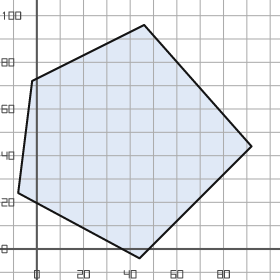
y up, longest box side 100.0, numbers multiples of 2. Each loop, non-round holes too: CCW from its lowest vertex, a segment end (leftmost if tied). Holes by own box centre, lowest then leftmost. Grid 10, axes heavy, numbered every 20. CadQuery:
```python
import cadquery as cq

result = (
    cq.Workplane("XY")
    .moveTo(44.0, -4.0)
    .lineTo(92.0, 44.0)
    .lineTo(46.0, 96.0)
    .lineTo(-2.0, 72.0)
    .lineTo(-8.0, 24.0)
    .close()
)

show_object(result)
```